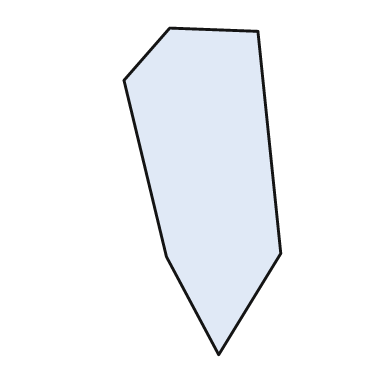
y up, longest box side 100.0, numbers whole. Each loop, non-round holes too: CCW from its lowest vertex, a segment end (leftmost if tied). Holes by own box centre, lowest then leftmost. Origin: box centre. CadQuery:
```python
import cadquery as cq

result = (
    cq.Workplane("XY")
    .moveTo(5.0, -50.0)
    .lineTo(24.0, -19.0)
    .lineTo(17.0, 49.0)
    .lineTo(-10.0, 50.0)
    .lineTo(-24.0, 34.0)
    .lineTo(-11.0, -20.0)
    .close()
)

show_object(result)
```